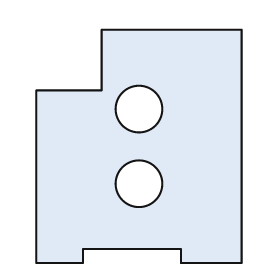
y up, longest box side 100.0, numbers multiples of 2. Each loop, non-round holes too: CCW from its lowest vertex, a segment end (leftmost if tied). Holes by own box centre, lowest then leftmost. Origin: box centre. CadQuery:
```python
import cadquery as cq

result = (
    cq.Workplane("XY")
    .moveTo(-44.0, -50.0)
    .lineTo(-24.0, -50.0)
    .lineTo(-24.0, -44.0)
    .lineTo(18.0, -44.0)
    .lineTo(18.0, -50.0)
    .lineTo(44.0, -50.0)
    .lineTo(44.0, 50.0)
    .lineTo(-16.0, 50.0)
    .lineTo(-16.0, 24.0)
    .lineTo(-44.0, 24.0)
    .close()
    .moveTo(0.0, -16.0)
    .circle(10.0)
    .moveTo(0.0, 16.0)
    .circle(10.0)
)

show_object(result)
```